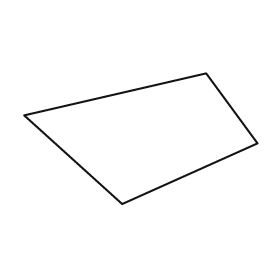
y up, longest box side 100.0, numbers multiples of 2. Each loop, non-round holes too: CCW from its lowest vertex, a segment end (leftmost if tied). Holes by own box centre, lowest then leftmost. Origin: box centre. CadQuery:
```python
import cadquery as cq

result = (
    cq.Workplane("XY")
    .moveTo(-8.0, -28.0)
    .lineTo(50.0, -2.0)
    .lineTo(28.0, 28.0)
    .lineTo(-50.0, 10.0)
    .close()
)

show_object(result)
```